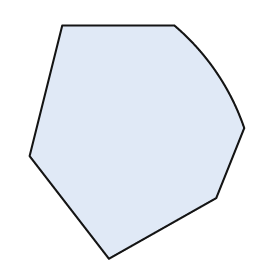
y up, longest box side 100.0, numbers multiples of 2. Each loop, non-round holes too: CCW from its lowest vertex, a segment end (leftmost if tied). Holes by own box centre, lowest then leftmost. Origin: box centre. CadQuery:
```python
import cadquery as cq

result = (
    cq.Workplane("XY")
    .moveTo(-12.0, -50.0)
    .lineTo(34.0, -24.0)
    .lineTo(46.0, 6.0)
    .threePointArc((34.0, 30.0), (16.0, 50.0))
    .lineTo(-32.0, 50.0)
    .lineTo(-46.0, -6.0)
    .close()
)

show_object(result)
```